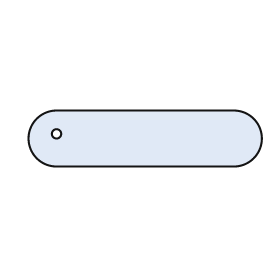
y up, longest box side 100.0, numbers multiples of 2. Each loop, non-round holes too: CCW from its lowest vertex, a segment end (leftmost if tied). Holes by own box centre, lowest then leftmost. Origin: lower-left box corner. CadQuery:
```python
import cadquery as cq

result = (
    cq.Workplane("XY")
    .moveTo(12.0, 0.0)
    .lineTo(88.0, 0.0)
    .threePointArc((100.0, 12.0), (88.0, 24.0))
    .lineTo(12.0, 24.0)
    .threePointArc((0.0, 12.0), (12.0, 0.0))
    .close()
    .moveTo(12.0, 14.0)
    .circle(2.0)
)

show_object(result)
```